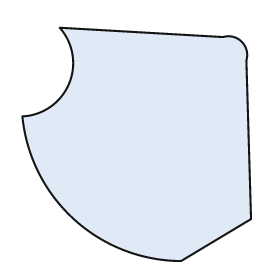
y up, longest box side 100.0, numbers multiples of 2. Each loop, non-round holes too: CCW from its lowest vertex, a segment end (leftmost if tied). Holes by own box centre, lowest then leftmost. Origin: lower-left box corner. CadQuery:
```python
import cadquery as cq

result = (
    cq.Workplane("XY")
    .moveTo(68.0, 0.0)
    .lineTo(98.0, 18.0)
    .lineTo(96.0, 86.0)
    .threePointArc((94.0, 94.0), (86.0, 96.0))
    .lineTo(16.0, 100.0)
    .threePointArc((20.0, 76.0), (0.0, 62.0))
    .threePointArc((22.0, 18.0), (68.0, 0.0))
    .close()
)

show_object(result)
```